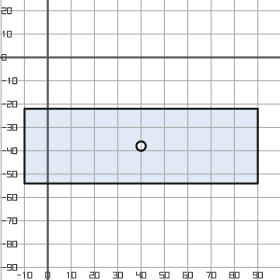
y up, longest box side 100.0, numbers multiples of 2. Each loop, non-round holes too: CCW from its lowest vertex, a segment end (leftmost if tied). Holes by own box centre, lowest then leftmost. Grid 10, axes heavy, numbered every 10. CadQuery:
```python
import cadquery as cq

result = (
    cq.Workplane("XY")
    .moveTo(-10.0, -54.0)
    .lineTo(90.0, -54.0)
    .lineTo(90.0, -22.0)
    .lineTo(-10.0, -22.0)
    .close()
    .moveTo(40.0, -38.0)
    .circle(2.0)
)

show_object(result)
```